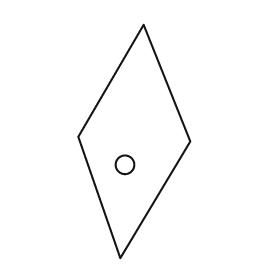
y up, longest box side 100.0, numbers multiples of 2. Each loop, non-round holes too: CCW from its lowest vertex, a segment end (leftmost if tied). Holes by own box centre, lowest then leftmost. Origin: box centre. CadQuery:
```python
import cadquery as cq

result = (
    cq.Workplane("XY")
    .moveTo(-6.0, -50.0)
    .lineTo(24.0, 0.0)
    .lineTo(4.0, 50.0)
    .lineTo(-24.0, 2.0)
    .close()
    .moveTo(-4.0, -10.0)
    .circle(4.0)
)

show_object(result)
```